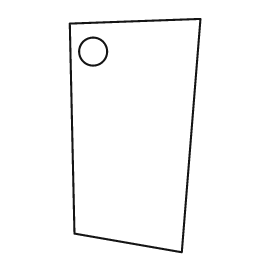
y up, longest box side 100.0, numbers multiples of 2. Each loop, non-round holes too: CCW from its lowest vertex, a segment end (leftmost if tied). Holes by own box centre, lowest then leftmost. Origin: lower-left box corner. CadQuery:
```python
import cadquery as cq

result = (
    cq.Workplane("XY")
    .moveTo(48.0, 0.0)
    .lineTo(56.0, 100.0)
    .lineTo(0.0, 98.0)
    .lineTo(2.0, 8.0)
    .close()
    .moveTo(10.0, 86.0)
    .circle(6.0)
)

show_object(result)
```